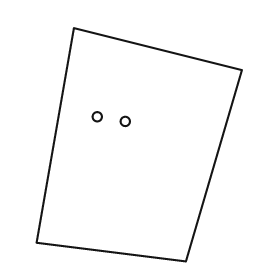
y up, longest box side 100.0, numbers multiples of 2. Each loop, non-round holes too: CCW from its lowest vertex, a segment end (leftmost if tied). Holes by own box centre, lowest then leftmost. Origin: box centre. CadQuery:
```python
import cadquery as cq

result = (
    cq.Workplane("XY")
    .moveTo(20.0, -50.0)
    .lineTo(44.0, 32.0)
    .lineTo(-28.0, 50.0)
    .lineTo(-44.0, -42.0)
    .close()
    .moveTo(-6.0, 10.0)
    .circle(2.0)
    .moveTo(-18.0, 12.0)
    .circle(2.0)
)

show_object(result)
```